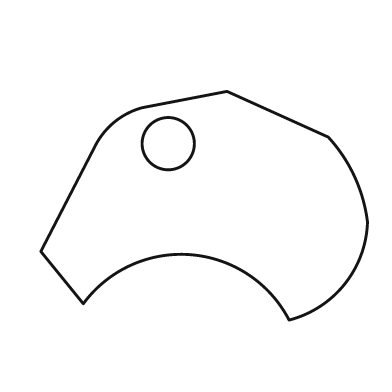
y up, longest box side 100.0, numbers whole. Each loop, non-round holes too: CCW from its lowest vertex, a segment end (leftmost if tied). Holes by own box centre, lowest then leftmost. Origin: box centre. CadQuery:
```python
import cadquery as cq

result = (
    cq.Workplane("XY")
    .moveTo(26.0, -35.0)
    .threePointArc((43.0, -24.0), (50.0, -5.0))
    .threePointArc((46.0, 9.0), (38.0, 21.0))
    .lineTo(7.0, 35.0)
    .lineTo(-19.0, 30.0)
    .threePointArc((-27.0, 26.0), (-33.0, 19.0))
    .lineTo(-50.0, -14.0)
    .lineTo(-37.0, -30.0)
    .threePointArc((-4.0, -15.0), (26.0, -35.0))
    .close()
    .moveTo(-11.0, 19.0)
    .circle(8.0)
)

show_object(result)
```